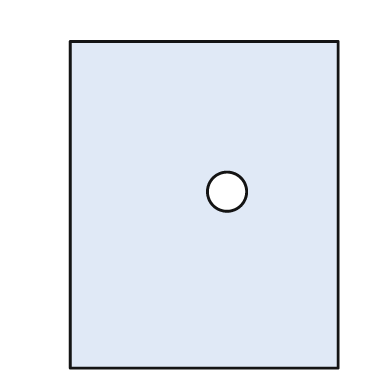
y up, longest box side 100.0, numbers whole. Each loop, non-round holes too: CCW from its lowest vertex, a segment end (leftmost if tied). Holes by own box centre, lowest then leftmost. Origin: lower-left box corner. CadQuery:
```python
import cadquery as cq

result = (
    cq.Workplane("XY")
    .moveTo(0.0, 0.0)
    .lineTo(82.0, 0.0)
    .lineTo(82.0, 100.0)
    .lineTo(0.0, 100.0)
    .close()
    .moveTo(48.0, 54.0)
    .circle(6.0)
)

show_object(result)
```